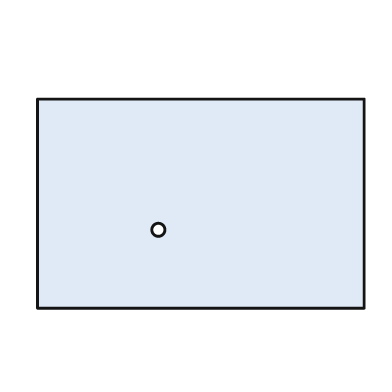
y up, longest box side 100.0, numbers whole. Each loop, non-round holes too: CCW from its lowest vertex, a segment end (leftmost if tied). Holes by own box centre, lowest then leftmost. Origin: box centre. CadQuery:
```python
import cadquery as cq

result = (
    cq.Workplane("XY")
    .moveTo(-50.0, -32.0)
    .lineTo(50.0, -32.0)
    .lineTo(50.0, 32.0)
    .lineTo(-50.0, 32.0)
    .close()
    .moveTo(-13.0, -8.0)
    .circle(2.0)
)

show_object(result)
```